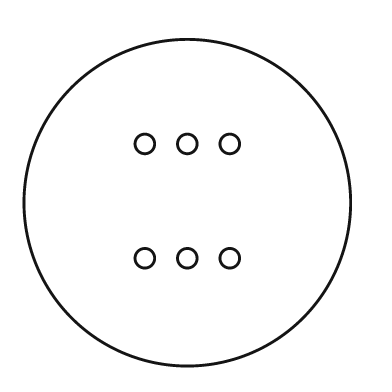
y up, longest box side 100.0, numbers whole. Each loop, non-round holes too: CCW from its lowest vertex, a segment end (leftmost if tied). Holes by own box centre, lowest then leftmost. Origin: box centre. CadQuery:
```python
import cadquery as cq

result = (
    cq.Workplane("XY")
    .moveTo(0.0, 0.0)
    .circle(50.0)
    .moveTo(-13.0, -17.0)
    .circle(3.0)
    .moveTo(0.0, -17.0)
    .circle(3.0)
    .moveTo(13.0, -17.0)
    .circle(3.0)
    .moveTo(-13.0, 18.0)
    .circle(3.0)
    .moveTo(0.0, 18.0)
    .circle(3.0)
    .moveTo(13.0, 18.0)
    .circle(3.0)
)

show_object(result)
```